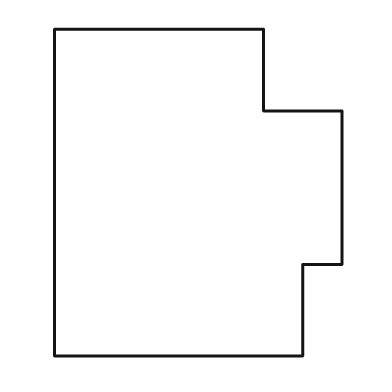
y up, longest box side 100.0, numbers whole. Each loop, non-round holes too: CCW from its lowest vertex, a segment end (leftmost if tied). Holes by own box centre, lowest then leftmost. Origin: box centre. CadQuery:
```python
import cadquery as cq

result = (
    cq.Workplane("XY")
    .moveTo(-44.0, -50.0)
    .lineTo(32.0, -50.0)
    .lineTo(32.0, -22.0)
    .lineTo(44.0, -22.0)
    .lineTo(44.0, 25.0)
    .lineTo(20.0, 25.0)
    .lineTo(20.0, 50.0)
    .lineTo(-44.0, 50.0)
    .close()
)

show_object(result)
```